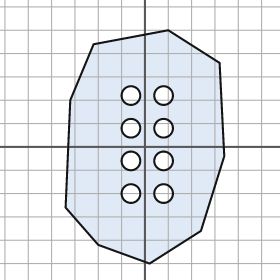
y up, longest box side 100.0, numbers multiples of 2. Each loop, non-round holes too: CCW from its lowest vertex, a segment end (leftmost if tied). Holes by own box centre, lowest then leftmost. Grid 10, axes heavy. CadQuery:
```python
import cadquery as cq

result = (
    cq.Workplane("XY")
    .moveTo(2.0, -50.0)
    .lineTo(24.0, -36.0)
    .lineTo(34.0, -4.0)
    .lineTo(32.0, 36.0)
    .lineTo(10.0, 50.0)
    .lineTo(-22.0, 44.0)
    .lineTo(-32.0, 20.0)
    .lineTo(-34.0, -26.0)
    .lineTo(-20.0, -42.0)
    .close()
    .moveTo(-6.0, -20.0)
    .circle(4.0)
    .moveTo(8.0, -20.0)
    .circle(4.0)
    .moveTo(-6.0, -6.0)
    .circle(4.0)
    .moveTo(8.0, -6.0)
    .circle(4.0)
    .moveTo(-6.0, 8.0)
    .circle(4.0)
    .moveTo(8.0, 8.0)
    .circle(4.0)
    .moveTo(-6.0, 22.0)
    .circle(4.0)
    .moveTo(8.0, 22.0)
    .circle(4.0)
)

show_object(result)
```